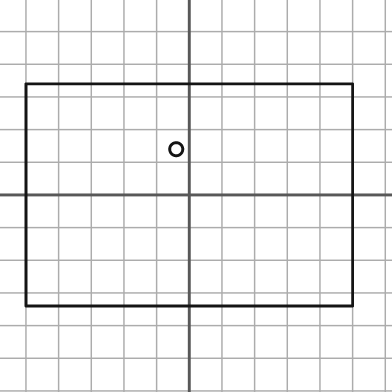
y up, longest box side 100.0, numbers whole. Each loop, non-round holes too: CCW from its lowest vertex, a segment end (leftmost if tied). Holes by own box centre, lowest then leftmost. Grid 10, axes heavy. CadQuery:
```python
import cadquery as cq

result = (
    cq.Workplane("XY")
    .moveTo(-50.0, -34.0)
    .lineTo(50.0, -34.0)
    .lineTo(50.0, 34.0)
    .lineTo(-50.0, 34.0)
    .close()
    .moveTo(-4.0, 14.0)
    .circle(2.0)
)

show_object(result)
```